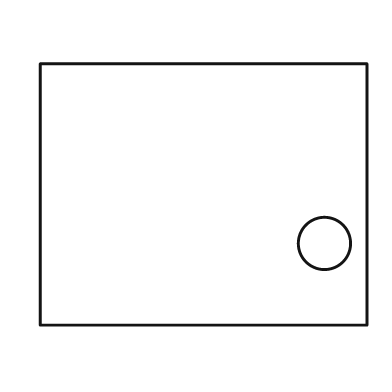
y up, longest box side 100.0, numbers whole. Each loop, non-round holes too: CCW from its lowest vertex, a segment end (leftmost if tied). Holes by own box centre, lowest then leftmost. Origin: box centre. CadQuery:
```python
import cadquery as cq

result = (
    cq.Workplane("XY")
    .moveTo(-50.0, -40.0)
    .lineTo(50.0, -40.0)
    .lineTo(50.0, 40.0)
    .lineTo(-50.0, 40.0)
    .close()
    .moveTo(37.0, -15.0)
    .circle(8.0)
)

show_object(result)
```